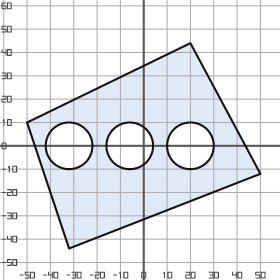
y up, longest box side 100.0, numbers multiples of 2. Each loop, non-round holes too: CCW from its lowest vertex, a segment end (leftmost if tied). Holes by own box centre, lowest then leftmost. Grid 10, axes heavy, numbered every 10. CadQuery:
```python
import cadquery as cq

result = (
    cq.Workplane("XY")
    .moveTo(-32.0, -44.0)
    .lineTo(50.0, -12.0)
    .lineTo(20.0, 44.0)
    .lineTo(-50.0, 10.0)
    .close()
    .moveTo(-32.0, 0.0)
    .circle(10.0)
    .moveTo(-6.0, 0.0)
    .circle(10.0)
    .moveTo(20.0, 0.0)
    .circle(10.0)
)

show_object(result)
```